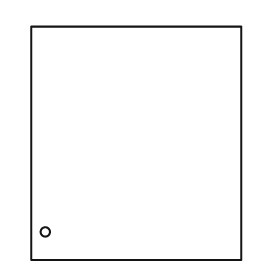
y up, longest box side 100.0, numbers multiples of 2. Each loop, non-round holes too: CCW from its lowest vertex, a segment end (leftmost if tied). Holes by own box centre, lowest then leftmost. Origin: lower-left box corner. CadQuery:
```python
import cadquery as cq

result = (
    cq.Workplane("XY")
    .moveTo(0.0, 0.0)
    .lineTo(90.0, 0.0)
    .lineTo(90.0, 100.0)
    .lineTo(0.0, 100.0)
    .close()
    .moveTo(6.0, 12.0)
    .circle(2.0)
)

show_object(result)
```